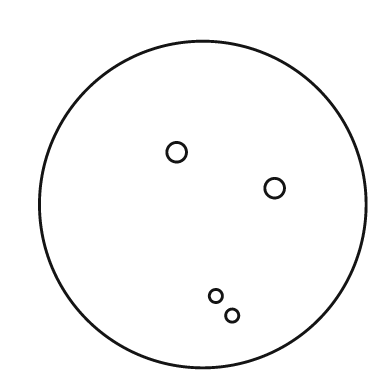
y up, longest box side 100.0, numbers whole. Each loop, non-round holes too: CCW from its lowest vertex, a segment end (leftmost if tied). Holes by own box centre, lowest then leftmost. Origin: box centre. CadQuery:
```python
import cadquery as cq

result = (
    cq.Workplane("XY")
    .moveTo(0.0, 0.0)
    .circle(50.0)
    .moveTo(9.0, -34.0)
    .circle(2.0)
    .moveTo(4.0, -28.0)
    .circle(2.0)
    .moveTo(22.0, 5.0)
    .circle(3.0)
    .moveTo(-8.0, 16.0)
    .circle(3.0)
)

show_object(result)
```